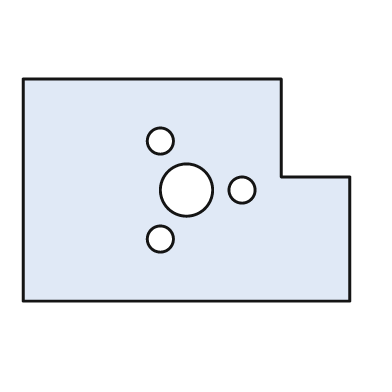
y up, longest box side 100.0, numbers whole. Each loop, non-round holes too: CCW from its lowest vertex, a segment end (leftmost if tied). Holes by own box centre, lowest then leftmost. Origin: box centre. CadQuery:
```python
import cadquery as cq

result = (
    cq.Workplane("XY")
    .moveTo(-50.0, -34.0)
    .lineTo(50.0, -34.0)
    .lineTo(50.0, 4.0)
    .lineTo(29.0, 4.0)
    .lineTo(29.0, 34.0)
    .lineTo(-50.0, 34.0)
    .close()
    .moveTo(-8.0, -15.0)
    .circle(4.0)
    .moveTo(0.0, 0.0)
    .circle(8.0)
    .moveTo(17.0, 0.0)
    .circle(4.0)
    .moveTo(-8.0, 15.0)
    .circle(4.0)
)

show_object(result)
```